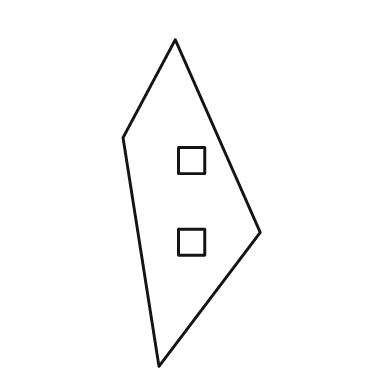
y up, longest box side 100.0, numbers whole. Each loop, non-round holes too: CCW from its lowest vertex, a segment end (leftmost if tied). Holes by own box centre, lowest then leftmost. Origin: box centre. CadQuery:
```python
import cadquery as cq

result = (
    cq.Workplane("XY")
    .moveTo(-10.0, -50.0)
    .lineTo(21.0, -9.0)
    .lineTo(-5.0, 50.0)
    .lineTo(-21.0, 20.0)
    .close()
    .moveTo(-4.0, -16.0)
    .lineTo(4.0, -16.0)
    .lineTo(4.0, -8.0)
    .lineTo(-4.0, -8.0)
    .close()
    .moveTo(-4.0, 9.0)
    .lineTo(4.0, 9.0)
    .lineTo(4.0, 17.0)
    .lineTo(-4.0, 17.0)
    .close()
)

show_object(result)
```